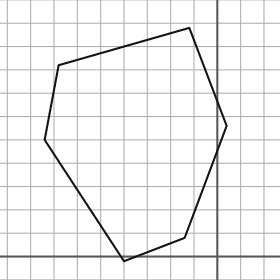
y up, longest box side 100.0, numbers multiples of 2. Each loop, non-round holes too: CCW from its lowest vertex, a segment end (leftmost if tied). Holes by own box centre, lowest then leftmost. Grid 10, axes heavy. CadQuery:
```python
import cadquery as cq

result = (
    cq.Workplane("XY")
    .moveTo(-40.0, -2.0)
    .lineTo(-14.0, 8.0)
    .lineTo(4.0, 56.0)
    .lineTo(-12.0, 98.0)
    .lineTo(-68.0, 82.0)
    .lineTo(-74.0, 50.0)
    .close()
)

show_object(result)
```